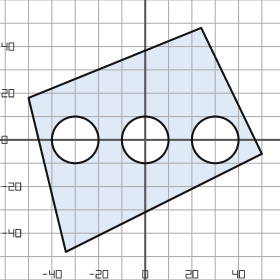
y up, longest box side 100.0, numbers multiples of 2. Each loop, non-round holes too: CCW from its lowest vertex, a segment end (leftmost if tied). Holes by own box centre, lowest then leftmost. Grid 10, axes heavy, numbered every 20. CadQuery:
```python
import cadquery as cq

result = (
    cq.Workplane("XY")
    .moveTo(-34.0, -48.0)
    .lineTo(50.0, -6.0)
    .lineTo(24.0, 48.0)
    .lineTo(-50.0, 18.0)
    .close()
    .moveTo(-30.0, 0.0)
    .circle(10.0)
    .moveTo(0.0, 0.0)
    .circle(10.0)
    .moveTo(30.0, 0.0)
    .circle(10.0)
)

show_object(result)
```